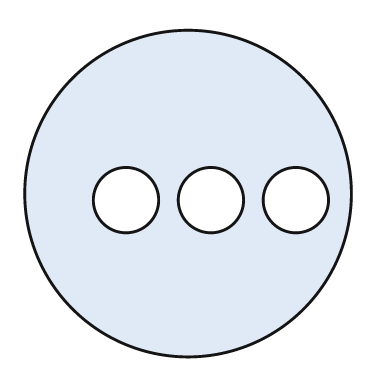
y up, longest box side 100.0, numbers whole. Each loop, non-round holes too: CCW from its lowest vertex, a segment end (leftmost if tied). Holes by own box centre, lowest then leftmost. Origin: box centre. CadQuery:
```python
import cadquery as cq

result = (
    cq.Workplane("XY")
    .moveTo(0.0, 0.0)
    .circle(50.0)
    .moveTo(-19.0, -2.0)
    .circle(10.0)
    .moveTo(7.0, -2.0)
    .circle(10.0)
    .moveTo(33.0, -2.0)
    .circle(10.0)
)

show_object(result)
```